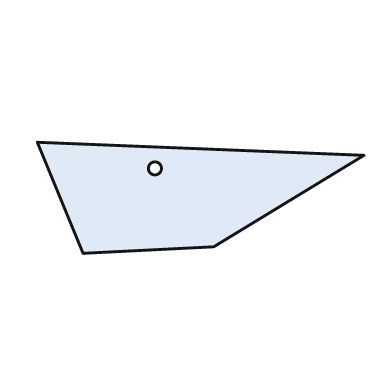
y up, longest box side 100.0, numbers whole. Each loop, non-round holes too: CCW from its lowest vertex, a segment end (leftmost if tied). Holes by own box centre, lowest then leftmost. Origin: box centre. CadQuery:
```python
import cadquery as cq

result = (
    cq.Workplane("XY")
    .moveTo(-36.0, -17.0)
    .lineTo(4.0, -15.0)
    .lineTo(50.0, 13.0)
    .lineTo(-50.0, 17.0)
    .close()
    .moveTo(-14.0, 9.0)
    .circle(2.0)
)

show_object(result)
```